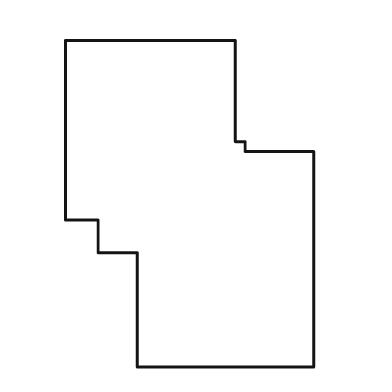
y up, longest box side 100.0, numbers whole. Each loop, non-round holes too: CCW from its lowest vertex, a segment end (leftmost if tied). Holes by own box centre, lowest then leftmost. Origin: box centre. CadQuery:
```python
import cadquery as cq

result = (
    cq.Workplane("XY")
    .moveTo(-16.0, -50.0)
    .lineTo(38.0, -50.0)
    .lineTo(38.0, 16.0)
    .lineTo(17.0, 16.0)
    .lineTo(17.0, 19.0)
    .lineTo(14.0, 19.0)
    .lineTo(14.0, 50.0)
    .lineTo(-38.0, 50.0)
    .lineTo(-38.0, -5.0)
    .lineTo(-28.0, -5.0)
    .lineTo(-28.0, -15.0)
    .lineTo(-16.0, -15.0)
    .close()
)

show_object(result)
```